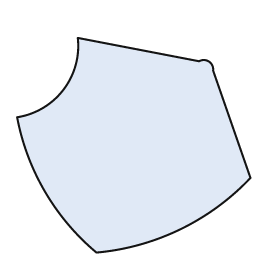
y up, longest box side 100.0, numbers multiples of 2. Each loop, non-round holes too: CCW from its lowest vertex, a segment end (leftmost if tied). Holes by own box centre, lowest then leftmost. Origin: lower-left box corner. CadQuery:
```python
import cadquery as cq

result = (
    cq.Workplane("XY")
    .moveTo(34.0, 0.0)
    .threePointArc((70.0, 10.0), (100.0, 32.0))
    .lineTo(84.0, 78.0)
    .threePointArc((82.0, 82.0), (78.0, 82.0))
    .lineTo(26.0, 92.0)
    .threePointArc((20.0, 70.0), (0.0, 58.0))
    .threePointArc((12.0, 26.0), (34.0, 0.0))
    .close()
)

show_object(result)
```